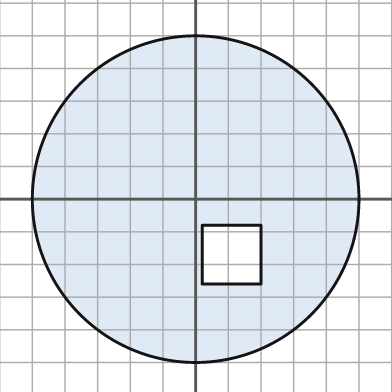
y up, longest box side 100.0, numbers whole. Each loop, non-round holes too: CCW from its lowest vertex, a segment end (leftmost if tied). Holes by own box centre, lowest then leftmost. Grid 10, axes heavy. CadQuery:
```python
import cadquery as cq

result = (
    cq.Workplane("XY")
    .moveTo(0.0, 0.0)
    .circle(50.0)
    .moveTo(2.0, -26.0)
    .lineTo(20.0, -26.0)
    .lineTo(20.0, -8.0)
    .lineTo(2.0, -8.0)
    .close()
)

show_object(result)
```